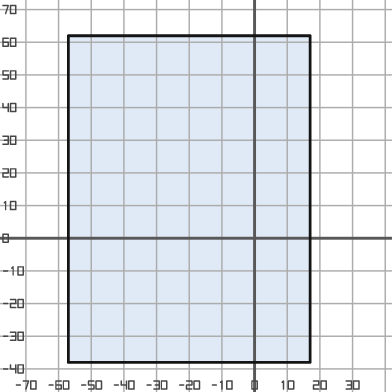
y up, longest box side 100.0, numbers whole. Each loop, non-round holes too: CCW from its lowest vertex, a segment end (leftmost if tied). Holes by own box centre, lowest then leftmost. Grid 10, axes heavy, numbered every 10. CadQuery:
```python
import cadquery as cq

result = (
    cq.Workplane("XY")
    .moveTo(-57.0, -38.0)
    .lineTo(17.0, -38.0)
    .lineTo(17.0, 62.0)
    .lineTo(-57.0, 62.0)
    .close()
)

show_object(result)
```